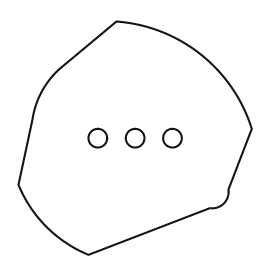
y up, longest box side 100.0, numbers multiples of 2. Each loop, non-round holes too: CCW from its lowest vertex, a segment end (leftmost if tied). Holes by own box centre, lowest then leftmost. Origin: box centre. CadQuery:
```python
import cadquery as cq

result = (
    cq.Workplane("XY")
    .moveTo(-20.0, -50.0)
    .lineTo(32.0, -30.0)
    .threePointArc((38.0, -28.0), (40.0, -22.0))
    .lineTo(50.0, 4.0)
    .threePointArc((28.0, 36.0), (-8.0, 50.0))
    .lineTo(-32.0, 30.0)
    .threePointArc((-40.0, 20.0), (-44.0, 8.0))
    .lineTo(-50.0, -20.0)
    .threePointArc((-38.0, -38.0), (-20.0, -50.0))
    .close()
    .moveTo(-16.0, 0.0)
    .circle(4.0)
    .moveTo(0.0, 0.0)
    .circle(4.0)
    .moveTo(16.0, 0.0)
    .circle(4.0)
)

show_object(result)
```